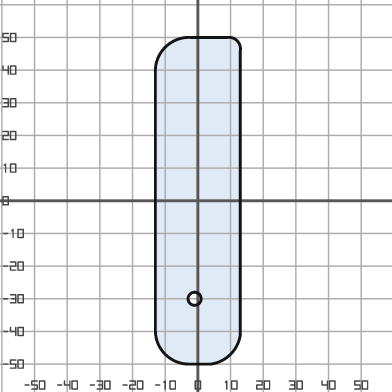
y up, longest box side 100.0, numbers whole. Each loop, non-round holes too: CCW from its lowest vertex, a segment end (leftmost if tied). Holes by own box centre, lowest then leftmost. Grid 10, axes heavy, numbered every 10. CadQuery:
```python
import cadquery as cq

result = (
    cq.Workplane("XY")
    .moveTo(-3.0, -50.0)
    .lineTo(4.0, -50.0)
    .threePointArc((10.0, -47.0), (13.0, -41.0))
    .lineTo(13.0, 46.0)
    .threePointArc((12.0, 49.0), (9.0, 50.0))
    .lineTo(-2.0, 50.0)
    .threePointArc((-10.0, 47.0), (-13.0, 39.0))
    .lineTo(-13.0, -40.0)
    .threePointArc((-10.0, -47.0), (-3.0, -50.0))
    .close()
    .moveTo(-1.0, -30.0)
    .circle(2.0)
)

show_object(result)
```